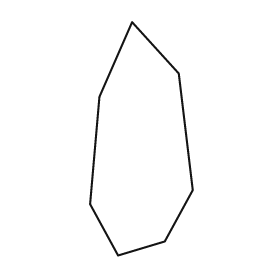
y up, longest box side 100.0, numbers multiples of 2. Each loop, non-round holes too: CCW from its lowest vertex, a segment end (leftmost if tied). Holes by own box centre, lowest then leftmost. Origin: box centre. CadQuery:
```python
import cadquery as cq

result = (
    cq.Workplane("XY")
    .moveTo(-10.0, -50.0)
    .lineTo(10.0, -44.0)
    .lineTo(22.0, -22.0)
    .lineTo(16.0, 28.0)
    .lineTo(-4.0, 50.0)
    .lineTo(-18.0, 18.0)
    .lineTo(-22.0, -28.0)
    .close()
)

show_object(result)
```